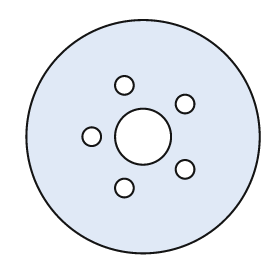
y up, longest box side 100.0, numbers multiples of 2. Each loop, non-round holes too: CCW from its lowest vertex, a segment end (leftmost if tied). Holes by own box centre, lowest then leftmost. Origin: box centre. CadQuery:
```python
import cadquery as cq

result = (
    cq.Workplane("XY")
    .moveTo(0.0, 0.0)
    .circle(50.0)
    .moveTo(-8.0, -22.0)
    .circle(4.0)
    .moveTo(18.0, -14.0)
    .circle(4.0)
    .moveTo(-22.0, 0.0)
    .circle(4.0)
    .moveTo(0.0, 0.0)
    .circle(12.0)
    .moveTo(18.0, 14.0)
    .circle(4.0)
    .moveTo(-8.0, 22.0)
    .circle(4.0)
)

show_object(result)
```